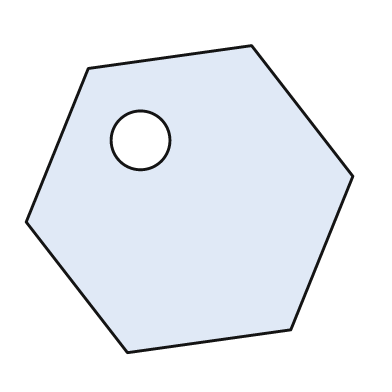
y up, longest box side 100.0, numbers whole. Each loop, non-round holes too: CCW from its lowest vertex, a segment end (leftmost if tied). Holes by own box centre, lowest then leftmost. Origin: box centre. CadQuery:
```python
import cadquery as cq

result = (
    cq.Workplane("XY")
    .moveTo(-19.0, -47.0)
    .lineTo(31.0, -40.0)
    .lineTo(50.0, 7.0)
    .lineTo(19.0, 47.0)
    .lineTo(-31.0, 40.0)
    .lineTo(-50.0, -7.0)
    .close()
    .moveTo(-15.0, 18.0)
    .circle(9.0)
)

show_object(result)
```